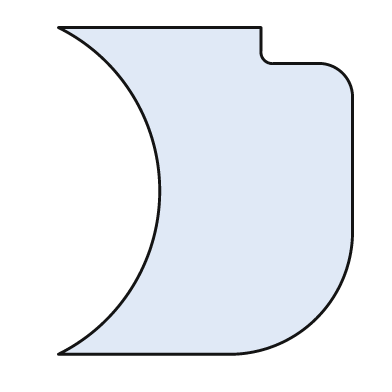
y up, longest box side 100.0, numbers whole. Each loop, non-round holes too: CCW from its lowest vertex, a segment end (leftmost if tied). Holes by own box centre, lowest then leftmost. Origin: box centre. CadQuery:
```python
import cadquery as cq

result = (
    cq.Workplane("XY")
    .moveTo(-45.0, -50.0)
    .lineTo(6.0, -50.0)
    .threePointArc((34.0, -39.0), (45.0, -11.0))
    .lineTo(45.0, 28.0)
    .threePointArc((42.0, 36.0), (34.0, 39.0))
    .lineTo(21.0, 39.0)
    .threePointArc((18.0, 40.0), (17.0, 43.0))
    .lineTo(17.0, 50.0)
    .lineTo(-45.0, 50.0)
    .threePointArc((-14.0, 0.0), (-45.0, -50.0))
    .close()
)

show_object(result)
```